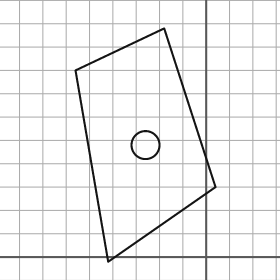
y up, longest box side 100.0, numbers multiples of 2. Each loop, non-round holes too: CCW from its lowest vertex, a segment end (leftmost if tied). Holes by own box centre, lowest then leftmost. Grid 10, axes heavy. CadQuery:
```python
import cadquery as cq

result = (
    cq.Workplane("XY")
    .moveTo(-42.0, -2.0)
    .lineTo(4.0, 30.0)
    .lineTo(-18.0, 98.0)
    .lineTo(-56.0, 80.0)
    .close()
    .moveTo(-26.0, 48.0)
    .circle(6.0)
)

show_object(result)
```